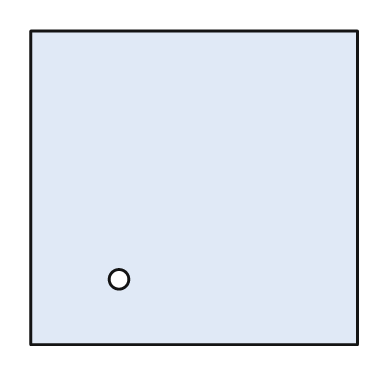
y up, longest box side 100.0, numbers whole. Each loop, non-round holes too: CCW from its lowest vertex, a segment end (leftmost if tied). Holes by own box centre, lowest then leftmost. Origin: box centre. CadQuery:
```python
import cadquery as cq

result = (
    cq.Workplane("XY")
    .moveTo(-50.0, -48.0)
    .lineTo(50.0, -48.0)
    .lineTo(50.0, 48.0)
    .lineTo(-50.0, 48.0)
    .close()
    .moveTo(-23.0, -28.0)
    .circle(3.0)
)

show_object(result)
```